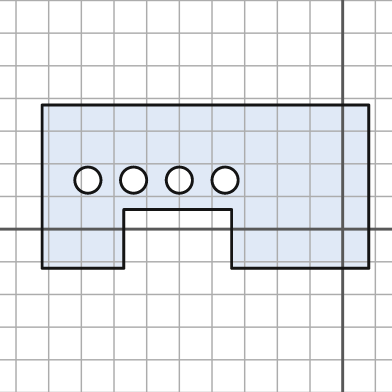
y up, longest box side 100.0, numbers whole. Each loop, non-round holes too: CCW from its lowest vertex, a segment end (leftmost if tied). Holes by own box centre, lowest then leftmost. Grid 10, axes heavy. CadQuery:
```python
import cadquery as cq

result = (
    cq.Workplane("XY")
    .moveTo(-92.0, -12.0)
    .lineTo(-67.0, -12.0)
    .lineTo(-67.0, 6.0)
    .lineTo(-34.0, 6.0)
    .lineTo(-34.0, -12.0)
    .lineTo(8.0, -12.0)
    .lineTo(8.0, 38.0)
    .lineTo(-92.0, 38.0)
    .close()
    .moveTo(-78.0, 15.0)
    .circle(4.0)
    .moveTo(-64.0, 15.0)
    .circle(4.0)
    .moveTo(-50.0, 15.0)
    .circle(4.0)
    .moveTo(-36.0, 15.0)
    .circle(4.0)
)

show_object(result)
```